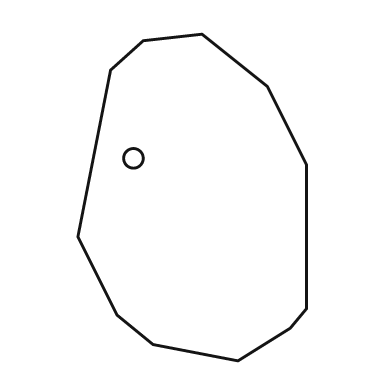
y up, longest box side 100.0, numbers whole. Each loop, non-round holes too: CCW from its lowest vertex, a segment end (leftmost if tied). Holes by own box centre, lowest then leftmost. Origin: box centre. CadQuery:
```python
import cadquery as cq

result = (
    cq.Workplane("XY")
    .moveTo(14.0, -50.0)
    .lineTo(30.0, -40.0)
    .lineTo(35.0, -34.0)
    .lineTo(35.0, 10.0)
    .lineTo(23.0, 34.0)
    .lineTo(3.0, 50.0)
    .lineTo(-15.0, 48.0)
    .lineTo(-25.0, 39.0)
    .lineTo(-35.0, -12.0)
    .lineTo(-23.0, -36.0)
    .lineTo(-12.0, -45.0)
    .close()
    .moveTo(-18.0, 12.0)
    .circle(3.0)
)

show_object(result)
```